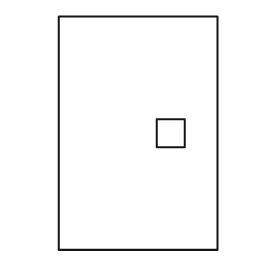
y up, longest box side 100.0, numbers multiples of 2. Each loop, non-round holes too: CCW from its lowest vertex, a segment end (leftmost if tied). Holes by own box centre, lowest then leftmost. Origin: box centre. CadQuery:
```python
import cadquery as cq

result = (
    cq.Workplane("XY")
    .moveTo(-34.0, -50.0)
    .lineTo(34.0, -50.0)
    .lineTo(34.0, 50.0)
    .lineTo(-34.0, 50.0)
    .close()
    .moveTo(8.0, -6.0)
    .lineTo(20.0, -6.0)
    .lineTo(20.0, 6.0)
    .lineTo(8.0, 6.0)
    .close()
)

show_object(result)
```